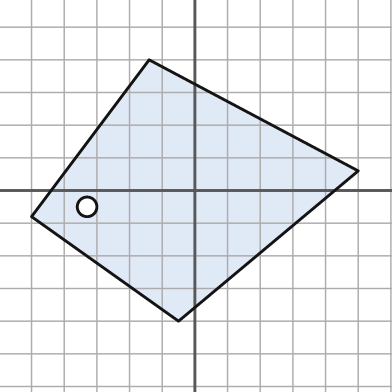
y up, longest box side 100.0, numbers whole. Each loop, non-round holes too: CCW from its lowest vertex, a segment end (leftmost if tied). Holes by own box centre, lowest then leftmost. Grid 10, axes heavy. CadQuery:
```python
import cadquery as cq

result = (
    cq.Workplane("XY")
    .moveTo(-5.0, -40.0)
    .lineTo(50.0, 6.0)
    .lineTo(-14.0, 40.0)
    .lineTo(-50.0, -8.0)
    .close()
    .moveTo(-33.0, -5.0)
    .circle(3.0)
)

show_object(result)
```